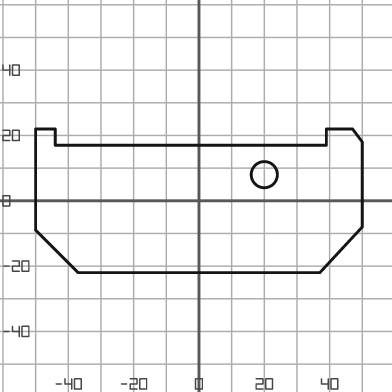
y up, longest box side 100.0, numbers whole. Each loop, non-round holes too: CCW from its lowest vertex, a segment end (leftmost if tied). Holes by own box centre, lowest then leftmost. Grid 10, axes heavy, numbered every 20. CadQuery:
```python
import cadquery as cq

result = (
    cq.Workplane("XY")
    .moveTo(-37.0, -22.0)
    .lineTo(37.0, -22.0)
    .lineTo(50.0, -8.0)
    .lineTo(50.0, 18.0)
    .lineTo(47.0, 22.0)
    .lineTo(39.0, 22.0)
    .lineTo(39.0, 17.0)
    .lineTo(-44.0, 17.0)
    .lineTo(-44.0, 22.0)
    .lineTo(-50.0, 22.0)
    .lineTo(-50.0, -9.0)
    .close()
    .moveTo(20.0, 8.0)
    .circle(4.0)
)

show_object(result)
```